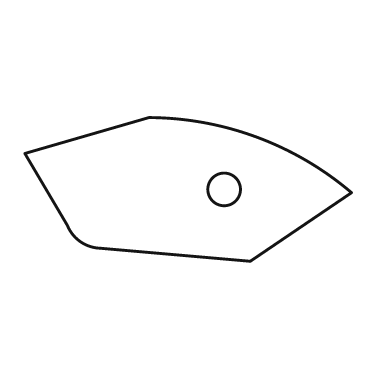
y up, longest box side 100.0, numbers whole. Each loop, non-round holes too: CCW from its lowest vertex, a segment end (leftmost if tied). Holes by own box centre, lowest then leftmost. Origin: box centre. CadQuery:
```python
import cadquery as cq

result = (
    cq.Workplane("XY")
    .moveTo(19.0, -22.0)
    .lineTo(50.0, -1.0)
    .threePointArc((21.0, 16.0), (-12.0, 22.0))
    .lineTo(-50.0, 11.0)
    .lineTo(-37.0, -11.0)
    .threePointArc((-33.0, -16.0), (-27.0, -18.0))
    .close()
    .moveTo(11.0, 0.0)
    .circle(5.0)
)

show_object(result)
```